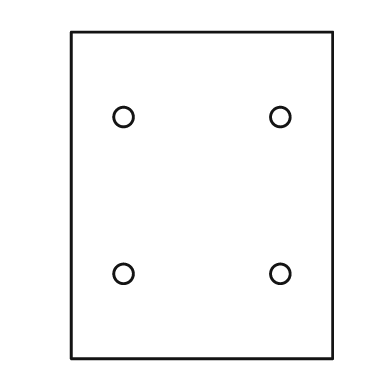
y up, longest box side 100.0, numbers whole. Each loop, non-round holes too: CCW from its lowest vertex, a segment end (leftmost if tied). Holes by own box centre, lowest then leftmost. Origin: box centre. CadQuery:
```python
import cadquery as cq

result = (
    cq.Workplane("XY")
    .moveTo(-40.0, -50.0)
    .lineTo(40.0, -50.0)
    .lineTo(40.0, 50.0)
    .lineTo(-40.0, 50.0)
    .close()
    .moveTo(-24.0, -24.0)
    .circle(3.0)
    .moveTo(24.0, -24.0)
    .circle(3.0)
    .moveTo(-24.0, 24.0)
    .circle(3.0)
    .moveTo(24.0, 24.0)
    .circle(3.0)
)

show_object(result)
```